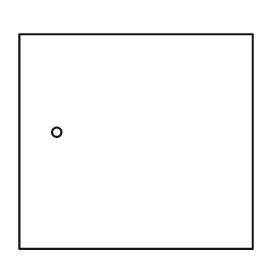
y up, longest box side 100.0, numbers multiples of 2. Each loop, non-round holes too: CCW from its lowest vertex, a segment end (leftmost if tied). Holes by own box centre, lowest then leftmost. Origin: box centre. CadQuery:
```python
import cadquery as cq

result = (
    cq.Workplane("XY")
    .moveTo(-50.0, -46.0)
    .lineTo(50.0, -46.0)
    .lineTo(50.0, 46.0)
    .lineTo(-50.0, 46.0)
    .close()
    .moveTo(-34.0, 4.0)
    .circle(2.0)
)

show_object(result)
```